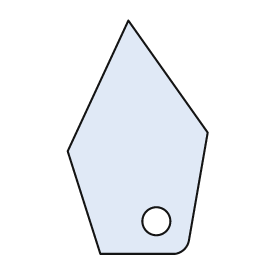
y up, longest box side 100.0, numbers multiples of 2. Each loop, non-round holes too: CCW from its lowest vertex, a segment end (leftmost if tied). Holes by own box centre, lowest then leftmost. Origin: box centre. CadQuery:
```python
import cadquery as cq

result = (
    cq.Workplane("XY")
    .moveTo(-16.0, -50.0)
    .lineTo(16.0, -50.0)
    .threePointArc((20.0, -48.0), (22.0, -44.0))
    .lineTo(30.0, 2.0)
    .lineTo(-4.0, 50.0)
    .lineTo(-30.0, -6.0)
    .close()
    .moveTo(8.0, -36.0)
    .circle(6.0)
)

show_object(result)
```